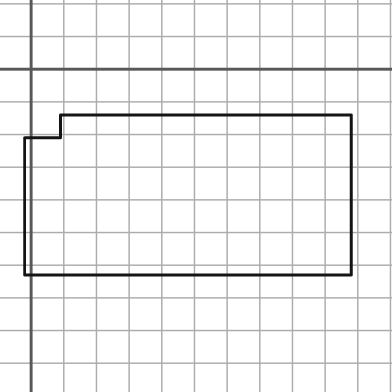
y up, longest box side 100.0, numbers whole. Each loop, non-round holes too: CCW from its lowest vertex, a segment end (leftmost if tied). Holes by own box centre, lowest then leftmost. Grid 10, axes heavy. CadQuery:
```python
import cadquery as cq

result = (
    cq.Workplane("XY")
    .moveTo(-2.0, -63.0)
    .lineTo(98.0, -63.0)
    .lineTo(98.0, -14.0)
    .lineTo(9.0, -14.0)
    .lineTo(9.0, -21.0)
    .lineTo(-2.0, -21.0)
    .close()
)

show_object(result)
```